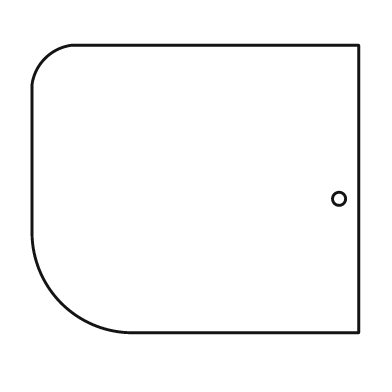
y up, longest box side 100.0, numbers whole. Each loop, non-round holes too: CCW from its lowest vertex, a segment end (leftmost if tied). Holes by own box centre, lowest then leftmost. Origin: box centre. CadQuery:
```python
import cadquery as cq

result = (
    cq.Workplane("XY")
    .moveTo(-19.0, -44.0)
    .lineTo(50.0, -44.0)
    .lineTo(50.0, 44.0)
    .lineTo(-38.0, 44.0)
    .threePointArc((-46.0, 40.0), (-50.0, 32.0))
    .lineTo(-50.0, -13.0)
    .threePointArc((-41.0, -35.0), (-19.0, -44.0))
    .close()
    .moveTo(44.0, -3.0)
    .circle(2.0)
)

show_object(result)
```